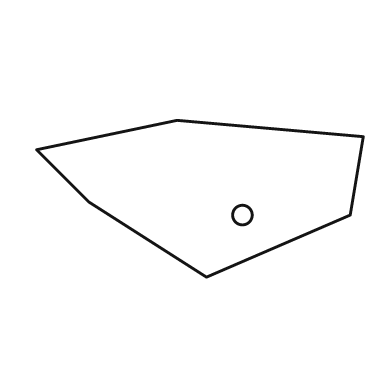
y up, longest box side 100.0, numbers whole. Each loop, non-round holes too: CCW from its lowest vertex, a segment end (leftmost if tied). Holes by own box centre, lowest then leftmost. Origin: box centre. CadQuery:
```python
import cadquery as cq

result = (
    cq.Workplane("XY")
    .moveTo(2.0, -24.0)
    .lineTo(46.0, -5.0)
    .lineTo(50.0, 19.0)
    .lineTo(-7.0, 24.0)
    .lineTo(-50.0, 15.0)
    .lineTo(-34.0, -1.0)
    .close()
    .moveTo(13.0, -5.0)
    .circle(3.0)
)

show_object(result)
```